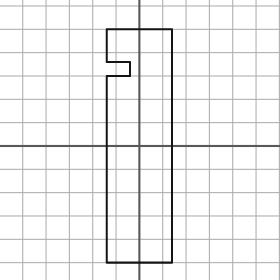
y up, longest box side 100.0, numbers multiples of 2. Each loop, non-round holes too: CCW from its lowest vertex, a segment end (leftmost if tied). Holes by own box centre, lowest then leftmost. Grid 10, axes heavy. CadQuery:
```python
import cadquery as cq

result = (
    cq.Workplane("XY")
    .moveTo(-14.0, -50.0)
    .lineTo(14.0, -50.0)
    .lineTo(14.0, 50.0)
    .lineTo(-14.0, 50.0)
    .lineTo(-14.0, 36.0)
    .lineTo(-4.0, 36.0)
    .lineTo(-4.0, 30.0)
    .lineTo(-14.0, 30.0)
    .close()
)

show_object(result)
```